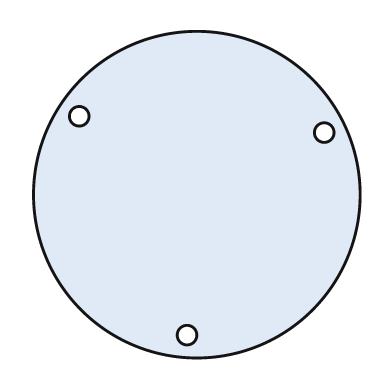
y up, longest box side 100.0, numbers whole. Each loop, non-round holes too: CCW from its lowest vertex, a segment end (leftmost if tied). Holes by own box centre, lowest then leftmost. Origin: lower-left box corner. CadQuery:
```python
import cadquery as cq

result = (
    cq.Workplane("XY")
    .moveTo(50.0, 50.0)
    .circle(50.0)
    .moveTo(47.0, 7.0)
    .circle(3.0)
    .moveTo(89.0, 69.0)
    .circle(3.0)
    .moveTo(14.0, 74.0)
    .circle(3.0)
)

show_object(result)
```